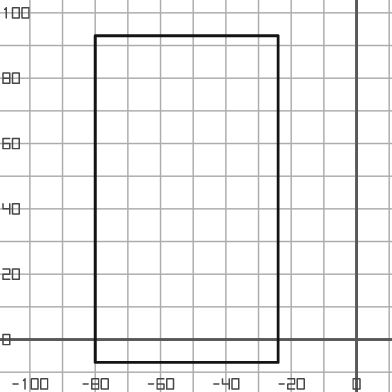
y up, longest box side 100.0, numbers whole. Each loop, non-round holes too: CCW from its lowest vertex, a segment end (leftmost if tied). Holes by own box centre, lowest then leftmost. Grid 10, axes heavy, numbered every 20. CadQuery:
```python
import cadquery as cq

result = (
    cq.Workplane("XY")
    .moveTo(-80.0, -7.0)
    .lineTo(-24.0, -7.0)
    .lineTo(-24.0, 93.0)
    .lineTo(-80.0, 93.0)
    .close()
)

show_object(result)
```